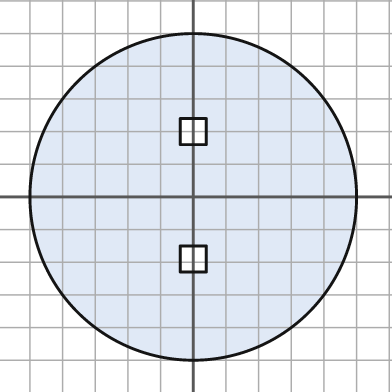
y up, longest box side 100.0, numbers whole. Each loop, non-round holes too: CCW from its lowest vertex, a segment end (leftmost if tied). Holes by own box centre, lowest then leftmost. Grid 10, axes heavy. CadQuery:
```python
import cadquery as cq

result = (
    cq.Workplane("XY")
    .moveTo(0.0, 0.0)
    .circle(50.0)
    .moveTo(-4.0, -23.0)
    .lineTo(4.0, -23.0)
    .lineTo(4.0, -15.0)
    .lineTo(-4.0, -15.0)
    .close()
    .moveTo(-4.0, 16.0)
    .lineTo(4.0, 16.0)
    .lineTo(4.0, 24.0)
    .lineTo(-4.0, 24.0)
    .close()
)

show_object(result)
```